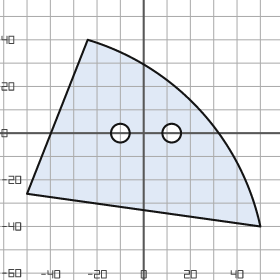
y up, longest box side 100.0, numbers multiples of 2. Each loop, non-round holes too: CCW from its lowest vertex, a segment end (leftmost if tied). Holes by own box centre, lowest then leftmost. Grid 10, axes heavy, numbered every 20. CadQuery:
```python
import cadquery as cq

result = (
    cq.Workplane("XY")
    .moveTo(50.0, -40.0)
    .threePointArc((24.0, 10.0), (-24.0, 40.0))
    .lineTo(-50.0, -26.0)
    .close()
    .moveTo(-10.0, 0.0)
    .circle(4.0)
    .moveTo(12.0, 0.0)
    .circle(4.0)
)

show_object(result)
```